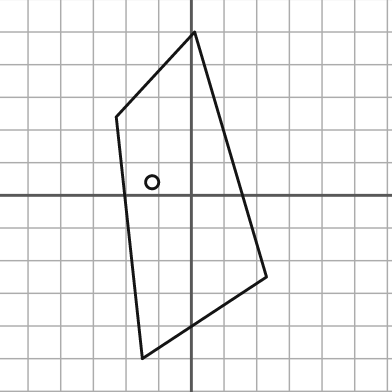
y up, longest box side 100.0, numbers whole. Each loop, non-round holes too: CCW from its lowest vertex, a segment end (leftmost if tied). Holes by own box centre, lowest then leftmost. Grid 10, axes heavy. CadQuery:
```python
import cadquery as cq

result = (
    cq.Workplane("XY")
    .moveTo(-15.0, -50.0)
    .lineTo(23.0, -25.0)
    .lineTo(1.0, 50.0)
    .lineTo(-23.0, 24.0)
    .close()
    .moveTo(-12.0, 4.0)
    .circle(2.0)
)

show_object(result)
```